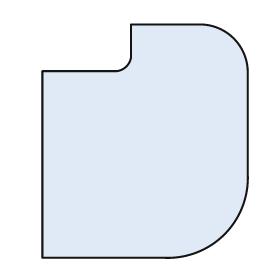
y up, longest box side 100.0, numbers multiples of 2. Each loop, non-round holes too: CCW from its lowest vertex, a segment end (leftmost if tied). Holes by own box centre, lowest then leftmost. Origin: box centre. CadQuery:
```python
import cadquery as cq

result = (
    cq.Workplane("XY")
    .moveTo(-44.0, -50.0)
    .lineTo(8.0, -50.0)
    .threePointArc((34.0, -40.0), (44.0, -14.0))
    .lineTo(44.0, 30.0)
    .threePointArc((38.0, 44.0), (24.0, 50.0))
    .lineTo(-6.0, 50.0)
    .lineTo(-6.0, 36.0)
    .threePointArc((-8.0, 32.0), (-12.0, 30.0))
    .lineTo(-44.0, 30.0)
    .close()
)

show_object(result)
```